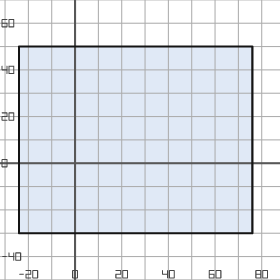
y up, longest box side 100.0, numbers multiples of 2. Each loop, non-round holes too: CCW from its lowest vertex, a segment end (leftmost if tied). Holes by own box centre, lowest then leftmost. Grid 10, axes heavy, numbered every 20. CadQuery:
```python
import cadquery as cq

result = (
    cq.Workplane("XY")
    .moveTo(-24.0, -30.0)
    .lineTo(76.0, -30.0)
    .lineTo(76.0, 50.0)
    .lineTo(-24.0, 50.0)
    .close()
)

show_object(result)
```